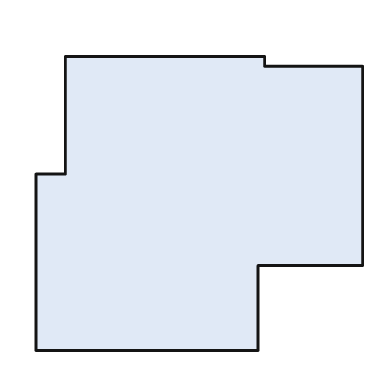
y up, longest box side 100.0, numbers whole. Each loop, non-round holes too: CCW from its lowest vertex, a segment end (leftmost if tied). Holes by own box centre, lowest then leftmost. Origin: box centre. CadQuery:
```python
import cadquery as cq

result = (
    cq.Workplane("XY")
    .moveTo(-50.0, -45.0)
    .lineTo(18.0, -45.0)
    .lineTo(18.0, -19.0)
    .lineTo(50.0, -19.0)
    .lineTo(50.0, 42.0)
    .lineTo(20.0, 42.0)
    .lineTo(20.0, 45.0)
    .lineTo(-41.0, 45.0)
    .lineTo(-41.0, 9.0)
    .lineTo(-50.0, 9.0)
    .close()
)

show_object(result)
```